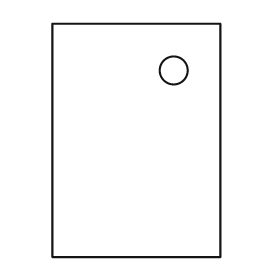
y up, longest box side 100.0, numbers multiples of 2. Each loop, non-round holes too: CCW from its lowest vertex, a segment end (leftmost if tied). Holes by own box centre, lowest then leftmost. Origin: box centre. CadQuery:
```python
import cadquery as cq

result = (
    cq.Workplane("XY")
    .moveTo(-36.0, -50.0)
    .lineTo(36.0, -50.0)
    .lineTo(36.0, 50.0)
    .lineTo(-36.0, 50.0)
    .close()
    .moveTo(16.0, 30.0)
    .circle(6.0)
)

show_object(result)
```